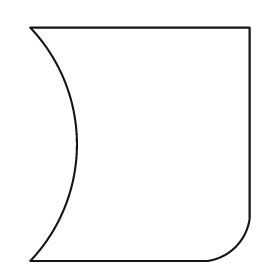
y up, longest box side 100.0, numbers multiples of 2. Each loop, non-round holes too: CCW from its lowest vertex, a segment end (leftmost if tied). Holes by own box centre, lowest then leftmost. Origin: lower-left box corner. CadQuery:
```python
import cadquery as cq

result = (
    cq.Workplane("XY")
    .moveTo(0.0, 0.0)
    .lineTo(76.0, 0.0)
    .threePointArc((88.0, 6.0), (94.0, 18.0))
    .lineTo(94.0, 100.0)
    .lineTo(0.0, 100.0)
    .threePointArc((20.0, 50.0), (0.0, 0.0))
    .close()
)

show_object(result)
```